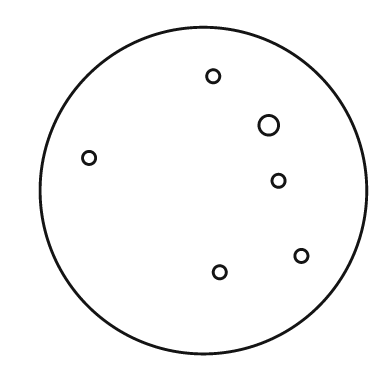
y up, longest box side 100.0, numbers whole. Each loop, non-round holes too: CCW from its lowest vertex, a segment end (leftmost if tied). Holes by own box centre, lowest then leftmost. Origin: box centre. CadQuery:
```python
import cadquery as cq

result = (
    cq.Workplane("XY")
    .moveTo(0.0, 0.0)
    .circle(50.0)
    .moveTo(5.0, -25.0)
    .circle(2.0)
    .moveTo(30.0, -20.0)
    .circle(2.0)
    .moveTo(23.0, 3.0)
    .circle(2.0)
    .moveTo(-35.0, 10.0)
    .circle(2.0)
    .moveTo(20.0, 20.0)
    .circle(3.0)
    .moveTo(3.0, 35.0)
    .circle(2.0)
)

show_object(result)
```